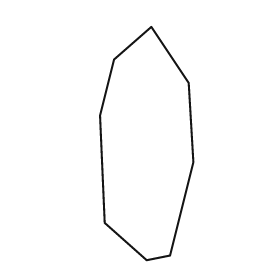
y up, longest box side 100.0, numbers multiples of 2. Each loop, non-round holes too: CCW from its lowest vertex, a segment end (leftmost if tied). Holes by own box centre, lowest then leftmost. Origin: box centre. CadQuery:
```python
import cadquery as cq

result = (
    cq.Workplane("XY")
    .moveTo(0.0, -50.0)
    .lineTo(10.0, -48.0)
    .lineTo(20.0, -8.0)
    .lineTo(18.0, 26.0)
    .lineTo(2.0, 50.0)
    .lineTo(-14.0, 36.0)
    .lineTo(-20.0, 12.0)
    .lineTo(-18.0, -34.0)
    .close()
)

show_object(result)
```